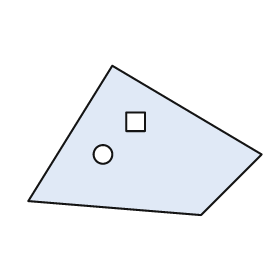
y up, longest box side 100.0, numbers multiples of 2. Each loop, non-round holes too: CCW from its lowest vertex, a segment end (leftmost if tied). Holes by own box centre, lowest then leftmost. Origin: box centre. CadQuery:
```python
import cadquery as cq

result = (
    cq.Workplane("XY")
    .moveTo(24.0, -32.0)
    .lineTo(50.0, -6.0)
    .lineTo(-14.0, 32.0)
    .lineTo(-50.0, -26.0)
    .close()
    .moveTo(-18.0, -6.0)
    .circle(4.0)
    .moveTo(-8.0, 4.0)
    .lineTo(0.0, 4.0)
    .lineTo(0.0, 12.0)
    .lineTo(-8.0, 12.0)
    .close()
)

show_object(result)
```